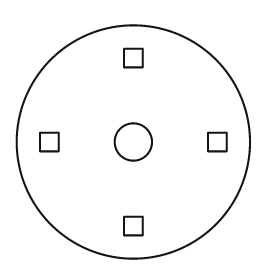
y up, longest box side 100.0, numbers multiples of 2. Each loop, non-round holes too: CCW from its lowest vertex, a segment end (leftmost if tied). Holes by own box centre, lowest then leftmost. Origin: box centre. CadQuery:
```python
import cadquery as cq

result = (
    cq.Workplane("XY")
    .moveTo(0.0, 0.0)
    .circle(50.0)
    .moveTo(-4.0, -40.0)
    .lineTo(4.0, -40.0)
    .lineTo(4.0, -32.0)
    .lineTo(-4.0, -32.0)
    .close()
    .moveTo(-40.0, -4.0)
    .lineTo(-32.0, -4.0)
    .lineTo(-32.0, 4.0)
    .lineTo(-40.0, 4.0)
    .close()
    .moveTo(0.0, 0.0)
    .circle(8.0)
    .moveTo(32.0, -4.0)
    .lineTo(40.0, -4.0)
    .lineTo(40.0, 4.0)
    .lineTo(32.0, 4.0)
    .close()
    .moveTo(-4.0, 32.0)
    .lineTo(4.0, 32.0)
    .lineTo(4.0, 40.0)
    .lineTo(-4.0, 40.0)
    .close()
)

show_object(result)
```